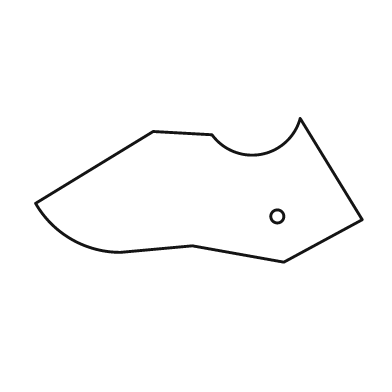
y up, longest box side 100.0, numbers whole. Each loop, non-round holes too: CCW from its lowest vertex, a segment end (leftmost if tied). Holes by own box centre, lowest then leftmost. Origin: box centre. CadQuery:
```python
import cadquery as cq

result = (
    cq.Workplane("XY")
    .moveTo(26.0, -22.0)
    .lineTo(50.0, -9.0)
    .lineTo(31.0, 22.0)
    .threePointArc((19.0, 11.0), (4.0, 17.0))
    .lineTo(-14.0, 18.0)
    .lineTo(-50.0, -4.0)
    .threePointArc((-39.0, -15.0), (-24.0, -19.0))
    .lineTo(-2.0, -17.0)
    .close()
    .moveTo(24.0, -8.0)
    .circle(2.0)
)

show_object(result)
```